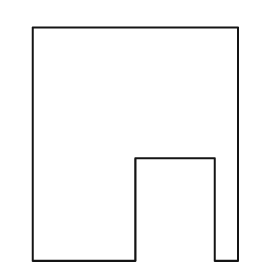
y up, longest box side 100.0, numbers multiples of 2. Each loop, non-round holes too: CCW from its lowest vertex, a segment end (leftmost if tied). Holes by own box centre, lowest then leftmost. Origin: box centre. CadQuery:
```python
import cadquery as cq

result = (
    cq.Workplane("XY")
    .moveTo(-44.0, -50.0)
    .lineTo(0.0, -50.0)
    .lineTo(0.0, -6.0)
    .lineTo(34.0, -6.0)
    .lineTo(34.0, -50.0)
    .lineTo(44.0, -50.0)
    .lineTo(44.0, 50.0)
    .lineTo(-44.0, 50.0)
    .close()
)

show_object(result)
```